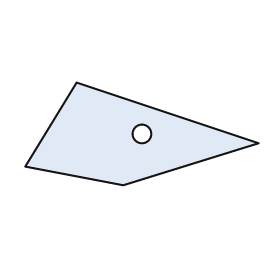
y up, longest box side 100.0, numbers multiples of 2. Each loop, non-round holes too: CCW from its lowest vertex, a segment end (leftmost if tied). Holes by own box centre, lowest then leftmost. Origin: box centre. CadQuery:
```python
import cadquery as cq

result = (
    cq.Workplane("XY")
    .moveTo(-8.0, -22.0)
    .lineTo(50.0, -4.0)
    .lineTo(-28.0, 22.0)
    .lineTo(-50.0, -14.0)
    .close()
    .moveTo(0.0, 0.0)
    .circle(4.0)
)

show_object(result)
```